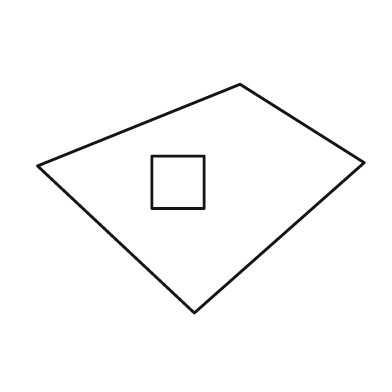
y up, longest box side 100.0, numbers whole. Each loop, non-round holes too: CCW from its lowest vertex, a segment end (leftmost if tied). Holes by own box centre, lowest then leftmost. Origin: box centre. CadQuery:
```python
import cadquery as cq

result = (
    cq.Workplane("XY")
    .moveTo(-2.0, -35.0)
    .lineTo(50.0, 11.0)
    .lineTo(12.0, 35.0)
    .lineTo(-50.0, 10.0)
    .close()
    .moveTo(-15.0, -3.0)
    .lineTo(1.0, -3.0)
    .lineTo(1.0, 13.0)
    .lineTo(-15.0, 13.0)
    .close()
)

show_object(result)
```